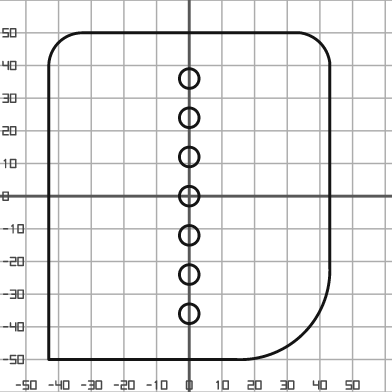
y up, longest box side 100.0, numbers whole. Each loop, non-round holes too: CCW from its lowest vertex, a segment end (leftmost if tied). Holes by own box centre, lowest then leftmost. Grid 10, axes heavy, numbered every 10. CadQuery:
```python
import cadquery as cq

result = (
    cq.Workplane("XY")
    .moveTo(-43.0, -50.0)
    .lineTo(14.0, -50.0)
    .threePointArc((35.0, -42.0), (43.0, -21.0))
    .lineTo(43.0, 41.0)
    .threePointArc((40.0, 47.0), (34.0, 50.0))
    .lineTo(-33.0, 50.0)
    .threePointArc((-40.0, 47.0), (-43.0, 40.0))
    .close()
    .moveTo(0.0, -36.0)
    .circle(3.0)
    .moveTo(0.0, -24.0)
    .circle(3.0)
    .moveTo(0.0, -12.0)
    .circle(3.0)
    .moveTo(0.0, 0.0)
    .circle(3.0)
    .moveTo(0.0, 12.0)
    .circle(3.0)
    .moveTo(0.0, 24.0)
    .circle(3.0)
    .moveTo(0.0, 36.0)
    .circle(3.0)
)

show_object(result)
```